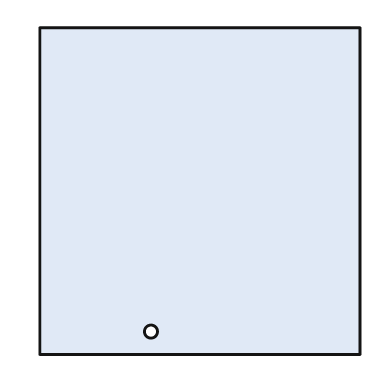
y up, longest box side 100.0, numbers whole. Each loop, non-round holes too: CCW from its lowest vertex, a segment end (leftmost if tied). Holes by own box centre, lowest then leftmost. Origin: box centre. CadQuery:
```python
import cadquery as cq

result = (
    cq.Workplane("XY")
    .moveTo(-49.0, -50.0)
    .lineTo(49.0, -50.0)
    .lineTo(49.0, 50.0)
    .lineTo(-49.0, 50.0)
    .close()
    .moveTo(-15.0, -43.0)
    .circle(2.0)
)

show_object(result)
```